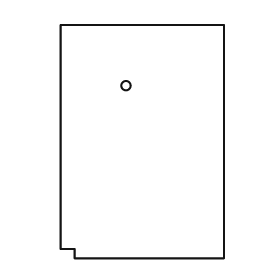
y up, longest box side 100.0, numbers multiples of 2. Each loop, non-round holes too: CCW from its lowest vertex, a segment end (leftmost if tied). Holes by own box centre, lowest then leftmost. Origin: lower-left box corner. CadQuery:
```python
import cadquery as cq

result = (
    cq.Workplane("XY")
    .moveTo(6.0, 0.0)
    .lineTo(70.0, 0.0)
    .lineTo(70.0, 100.0)
    .lineTo(0.0, 100.0)
    .lineTo(0.0, 4.0)
    .lineTo(6.0, 4.0)
    .close()
    .moveTo(28.0, 74.0)
    .circle(2.0)
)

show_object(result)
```